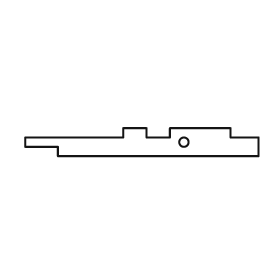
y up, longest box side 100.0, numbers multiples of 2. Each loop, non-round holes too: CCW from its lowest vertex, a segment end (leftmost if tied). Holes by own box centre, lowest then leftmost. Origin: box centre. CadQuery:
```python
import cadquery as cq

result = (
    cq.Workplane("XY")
    .moveTo(-36.0, -6.0)
    .lineTo(50.0, -6.0)
    .lineTo(50.0, 2.0)
    .lineTo(38.0, 2.0)
    .lineTo(38.0, 6.0)
    .lineTo(12.0, 6.0)
    .lineTo(12.0, 2.0)
    .lineTo(2.0, 2.0)
    .lineTo(2.0, 6.0)
    .lineTo(-8.0, 6.0)
    .lineTo(-8.0, 2.0)
    .lineTo(-50.0, 2.0)
    .lineTo(-50.0, -2.0)
    .lineTo(-36.0, -2.0)
    .close()
    .moveTo(18.0, 0.0)
    .circle(2.0)
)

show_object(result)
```